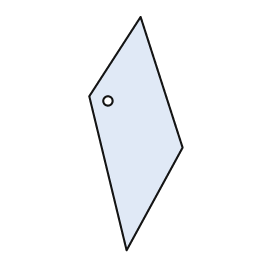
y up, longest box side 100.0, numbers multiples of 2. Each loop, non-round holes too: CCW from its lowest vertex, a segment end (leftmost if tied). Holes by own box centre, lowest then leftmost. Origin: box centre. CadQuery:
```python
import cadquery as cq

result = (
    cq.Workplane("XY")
    .moveTo(-4.0, -50.0)
    .lineTo(20.0, -6.0)
    .lineTo(2.0, 50.0)
    .lineTo(-20.0, 16.0)
    .close()
    .moveTo(-12.0, 14.0)
    .circle(2.0)
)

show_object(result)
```